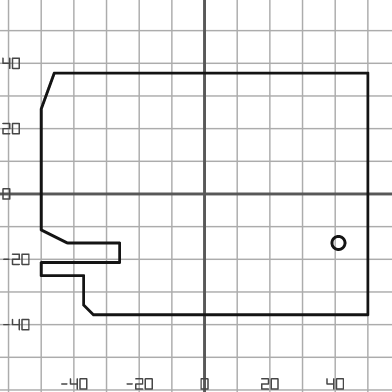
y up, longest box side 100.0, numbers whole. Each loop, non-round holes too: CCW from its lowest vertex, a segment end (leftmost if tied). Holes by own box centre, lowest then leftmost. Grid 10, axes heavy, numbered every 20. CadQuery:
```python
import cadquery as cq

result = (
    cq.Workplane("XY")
    .moveTo(-34.0, -37.0)
    .lineTo(50.0, -37.0)
    .lineTo(50.0, 37.0)
    .lineTo(-46.0, 37.0)
    .lineTo(-50.0, 26.0)
    .lineTo(-50.0, -11.0)
    .lineTo(-42.0, -15.0)
    .lineTo(-26.0, -15.0)
    .lineTo(-26.0, -21.0)
    .lineTo(-50.0, -21.0)
    .lineTo(-50.0, -25.0)
    .lineTo(-37.0, -25.0)
    .lineTo(-37.0, -34.0)
    .close()
    .moveTo(41.0, -15.0)
    .circle(2.0)
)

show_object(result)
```